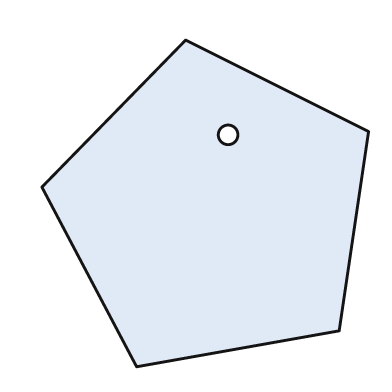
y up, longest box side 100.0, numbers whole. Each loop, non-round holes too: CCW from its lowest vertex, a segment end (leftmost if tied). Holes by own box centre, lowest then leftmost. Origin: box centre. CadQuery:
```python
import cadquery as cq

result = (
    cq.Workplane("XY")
    .moveTo(-21.0, -50.0)
    .lineTo(41.0, -39.0)
    .lineTo(50.0, 22.0)
    .lineTo(-6.0, 50.0)
    .lineTo(-50.0, 5.0)
    .close()
    .moveTo(7.0, 21.0)
    .circle(3.0)
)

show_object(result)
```